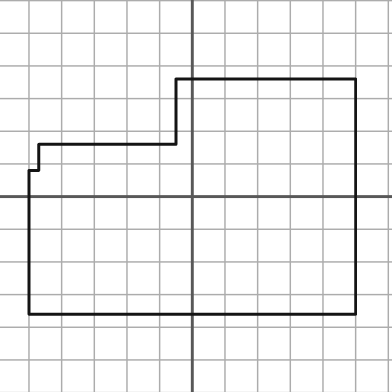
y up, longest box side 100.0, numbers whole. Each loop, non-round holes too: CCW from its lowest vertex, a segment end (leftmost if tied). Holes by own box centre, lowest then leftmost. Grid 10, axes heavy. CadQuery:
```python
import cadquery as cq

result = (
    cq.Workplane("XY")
    .moveTo(-50.0, -36.0)
    .lineTo(50.0, -36.0)
    .lineTo(50.0, 36.0)
    .lineTo(-5.0, 36.0)
    .lineTo(-5.0, 16.0)
    .lineTo(-47.0, 16.0)
    .lineTo(-47.0, 8.0)
    .lineTo(-50.0, 8.0)
    .close()
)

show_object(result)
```